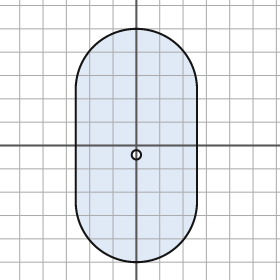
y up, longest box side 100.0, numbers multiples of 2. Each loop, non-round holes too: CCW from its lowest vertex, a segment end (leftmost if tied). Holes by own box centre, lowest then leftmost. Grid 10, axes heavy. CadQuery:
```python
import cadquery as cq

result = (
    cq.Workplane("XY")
    .moveTo(-26.0, -24.0)
    .threePointArc((0.0, -50.0), (26.0, -24.0))
    .lineTo(26.0, 24.0)
    .threePointArc((0.0, 50.0), (-26.0, 24.0))
    .close()
    .moveTo(0.0, -4.0)
    .circle(2.0)
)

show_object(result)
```